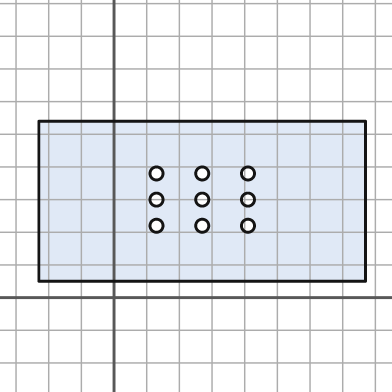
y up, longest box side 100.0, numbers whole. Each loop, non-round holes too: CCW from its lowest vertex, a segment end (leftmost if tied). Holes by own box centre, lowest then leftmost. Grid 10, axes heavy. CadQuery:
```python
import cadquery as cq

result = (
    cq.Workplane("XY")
    .moveTo(-23.0, 5.0)
    .lineTo(77.0, 5.0)
    .lineTo(77.0, 54.0)
    .lineTo(-23.0, 54.0)
    .close()
    .moveTo(13.0, 22.0)
    .circle(2.0)
    .moveTo(27.0, 22.0)
    .circle(2.0)
    .moveTo(41.0, 22.0)
    .circle(2.0)
    .moveTo(13.0, 30.0)
    .circle(2.0)
    .moveTo(27.0, 30.0)
    .circle(2.0)
    .moveTo(41.0, 30.0)
    .circle(2.0)
    .moveTo(13.0, 38.0)
    .circle(2.0)
    .moveTo(27.0, 38.0)
    .circle(2.0)
    .moveTo(41.0, 38.0)
    .circle(2.0)
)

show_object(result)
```